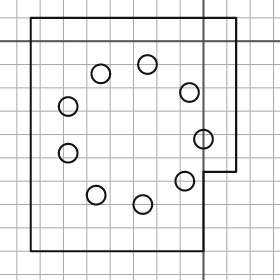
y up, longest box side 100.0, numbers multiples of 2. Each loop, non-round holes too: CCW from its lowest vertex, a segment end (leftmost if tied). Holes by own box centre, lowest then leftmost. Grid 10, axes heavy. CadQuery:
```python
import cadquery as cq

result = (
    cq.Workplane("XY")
    .moveTo(-74.0, -90.0)
    .lineTo(0.0, -90.0)
    .lineTo(0.0, -56.0)
    .lineTo(14.0, -56.0)
    .lineTo(14.0, 10.0)
    .lineTo(-74.0, 10.0)
    .close()
    .moveTo(-26.0, -70.0)
    .circle(4.0)
    .moveTo(-46.0, -66.0)
    .circle(4.0)
    .moveTo(-8.0, -60.0)
    .circle(4.0)
    .moveTo(-58.0, -48.0)
    .circle(4.0)
    .moveTo(0.0, -42.0)
    .circle(4.0)
    .moveTo(-58.0, -28.0)
    .circle(4.0)
    .moveTo(-6.0, -22.0)
    .circle(4.0)
    .moveTo(-44.0, -14.0)
    .circle(4.0)
    .moveTo(-24.0, -10.0)
    .circle(4.0)
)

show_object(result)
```